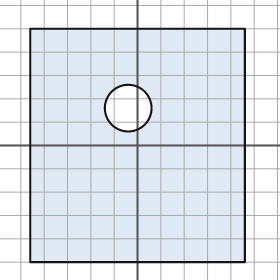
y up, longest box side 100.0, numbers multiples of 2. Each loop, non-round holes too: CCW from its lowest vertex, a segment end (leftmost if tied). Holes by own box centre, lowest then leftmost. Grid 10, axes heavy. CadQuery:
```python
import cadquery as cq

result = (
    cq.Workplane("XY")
    .moveTo(-46.0, -50.0)
    .lineTo(46.0, -50.0)
    .lineTo(46.0, 50.0)
    .lineTo(-46.0, 50.0)
    .close()
    .moveTo(-4.0, 16.0)
    .circle(10.0)
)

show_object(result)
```